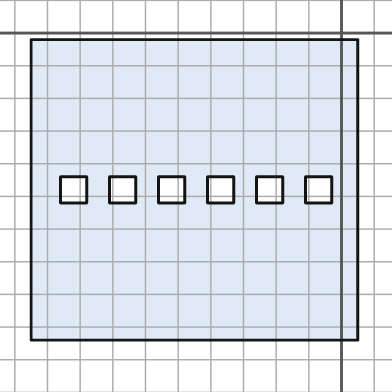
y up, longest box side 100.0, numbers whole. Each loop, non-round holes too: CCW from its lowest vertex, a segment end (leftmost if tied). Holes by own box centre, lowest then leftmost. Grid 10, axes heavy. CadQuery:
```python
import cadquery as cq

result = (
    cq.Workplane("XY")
    .moveTo(-95.0, -94.0)
    .lineTo(5.0, -94.0)
    .lineTo(5.0, -2.0)
    .lineTo(-95.0, -2.0)
    .close()
    .moveTo(-86.0, -52.0)
    .lineTo(-78.0, -52.0)
    .lineTo(-78.0, -44.0)
    .lineTo(-86.0, -44.0)
    .close()
    .moveTo(-71.0, -52.0)
    .lineTo(-63.0, -52.0)
    .lineTo(-63.0, -44.0)
    .lineTo(-71.0, -44.0)
    .close()
    .moveTo(-56.0, -52.0)
    .lineTo(-48.0, -52.0)
    .lineTo(-48.0, -44.0)
    .lineTo(-56.0, -44.0)
    .close()
    .moveTo(-41.0, -52.0)
    .lineTo(-33.0, -52.0)
    .lineTo(-33.0, -44.0)
    .lineTo(-41.0, -44.0)
    .close()
    .moveTo(-26.0, -52.0)
    .lineTo(-18.0, -52.0)
    .lineTo(-18.0, -44.0)
    .lineTo(-26.0, -44.0)
    .close()
    .moveTo(-11.0, -52.0)
    .lineTo(-3.0, -52.0)
    .lineTo(-3.0, -44.0)
    .lineTo(-11.0, -44.0)
    .close()
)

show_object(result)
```